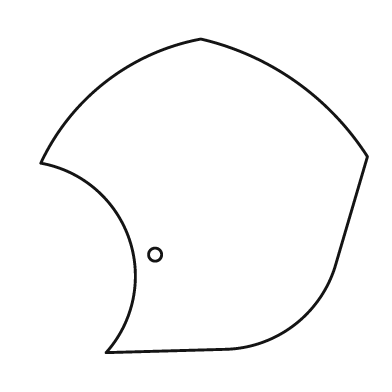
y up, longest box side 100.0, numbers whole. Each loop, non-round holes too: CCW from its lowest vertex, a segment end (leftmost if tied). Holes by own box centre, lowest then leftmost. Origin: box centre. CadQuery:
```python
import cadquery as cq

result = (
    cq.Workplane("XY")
    .moveTo(-30.0, -48.0)
    .lineTo(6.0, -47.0)
    .threePointArc((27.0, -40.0), (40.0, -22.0))
    .lineTo(50.0, 12.0)
    .threePointArc((28.0, 35.0), (-1.0, 48.0))
    .threePointArc((-30.0, 35.0), (-50.0, 10.0))
    .threePointArc((-23.0, -13.0), (-30.0, -48.0))
    .close()
    .moveTo(-15.0, -18.0)
    .circle(2.0)
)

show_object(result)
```